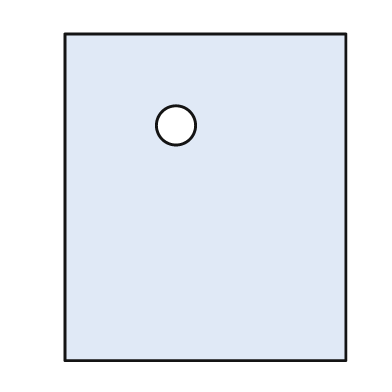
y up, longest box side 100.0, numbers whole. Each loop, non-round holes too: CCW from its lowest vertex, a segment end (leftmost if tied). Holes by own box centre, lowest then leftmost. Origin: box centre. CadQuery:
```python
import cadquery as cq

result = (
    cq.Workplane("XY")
    .moveTo(-43.0, -50.0)
    .lineTo(43.0, -50.0)
    .lineTo(43.0, 50.0)
    .lineTo(-43.0, 50.0)
    .close()
    .moveTo(-9.0, 22.0)
    .circle(6.0)
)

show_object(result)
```